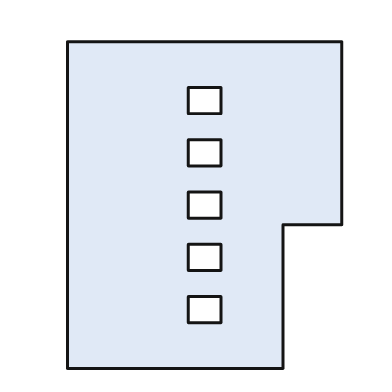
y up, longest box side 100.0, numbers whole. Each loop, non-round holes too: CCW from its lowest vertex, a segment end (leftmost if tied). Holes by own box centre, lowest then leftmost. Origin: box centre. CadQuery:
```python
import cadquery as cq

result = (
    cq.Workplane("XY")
    .moveTo(-42.0, -50.0)
    .lineTo(24.0, -50.0)
    .lineTo(24.0, -6.0)
    .lineTo(42.0, -6.0)
    .lineTo(42.0, 50.0)
    .lineTo(-42.0, 50.0)
    .close()
    .moveTo(-5.0, -36.0)
    .lineTo(5.0, -36.0)
    .lineTo(5.0, -28.0)
    .lineTo(-5.0, -28.0)
    .close()
    .moveTo(-5.0, -20.0)
    .lineTo(5.0, -20.0)
    .lineTo(5.0, -12.0)
    .lineTo(-5.0, -12.0)
    .close()
    .moveTo(-5.0, -4.0)
    .lineTo(5.0, -4.0)
    .lineTo(5.0, 4.0)
    .lineTo(-5.0, 4.0)
    .close()
    .moveTo(-5.0, 12.0)
    .lineTo(5.0, 12.0)
    .lineTo(5.0, 20.0)
    .lineTo(-5.0, 20.0)
    .close()
    .moveTo(-5.0, 28.0)
    .lineTo(5.0, 28.0)
    .lineTo(5.0, 36.0)
    .lineTo(-5.0, 36.0)
    .close()
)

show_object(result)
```